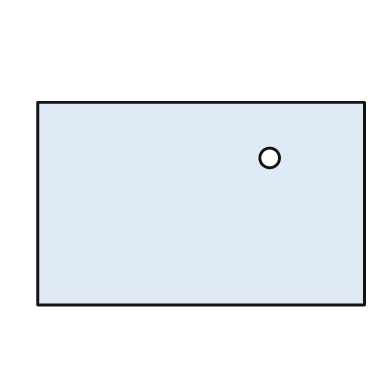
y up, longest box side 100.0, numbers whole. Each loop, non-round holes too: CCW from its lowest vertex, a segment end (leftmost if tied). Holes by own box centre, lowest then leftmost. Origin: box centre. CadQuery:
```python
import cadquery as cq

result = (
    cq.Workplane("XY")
    .moveTo(-50.0, -31.0)
    .lineTo(50.0, -31.0)
    .lineTo(50.0, 31.0)
    .lineTo(-50.0, 31.0)
    .close()
    .moveTo(21.0, 14.0)
    .circle(3.0)
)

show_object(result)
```